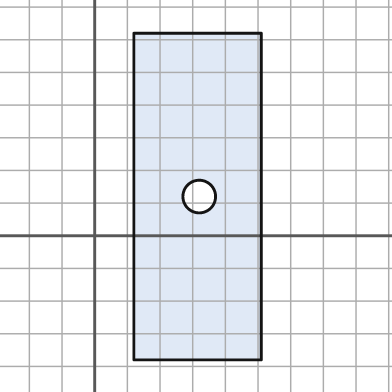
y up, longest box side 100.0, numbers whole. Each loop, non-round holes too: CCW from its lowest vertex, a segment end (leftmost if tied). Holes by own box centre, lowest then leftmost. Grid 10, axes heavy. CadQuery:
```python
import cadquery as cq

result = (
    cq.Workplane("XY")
    .moveTo(12.0, -38.0)
    .lineTo(51.0, -38.0)
    .lineTo(51.0, 62.0)
    .lineTo(12.0, 62.0)
    .close()
    .moveTo(32.0, 12.0)
    .circle(5.0)
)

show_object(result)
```